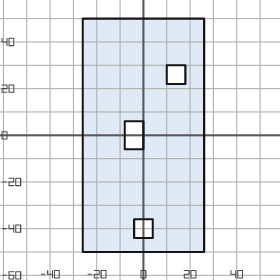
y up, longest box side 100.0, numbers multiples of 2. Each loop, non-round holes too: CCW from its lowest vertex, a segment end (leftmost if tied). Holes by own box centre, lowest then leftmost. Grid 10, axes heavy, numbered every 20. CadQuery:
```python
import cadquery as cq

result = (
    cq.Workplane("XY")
    .moveTo(-26.0, -50.0)
    .lineTo(26.0, -50.0)
    .lineTo(26.0, 50.0)
    .lineTo(-26.0, 50.0)
    .close()
    .moveTo(-4.0, -44.0)
    .lineTo(4.0, -44.0)
    .lineTo(4.0, -36.0)
    .lineTo(-4.0, -36.0)
    .close()
    .moveTo(-8.0, -6.0)
    .lineTo(0.0, -6.0)
    .lineTo(0.0, 6.0)
    .lineTo(-8.0, 6.0)
    .close()
    .moveTo(10.0, 22.0)
    .lineTo(18.0, 22.0)
    .lineTo(18.0, 30.0)
    .lineTo(10.0, 30.0)
    .close()
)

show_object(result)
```